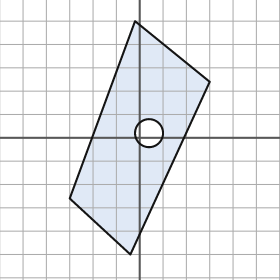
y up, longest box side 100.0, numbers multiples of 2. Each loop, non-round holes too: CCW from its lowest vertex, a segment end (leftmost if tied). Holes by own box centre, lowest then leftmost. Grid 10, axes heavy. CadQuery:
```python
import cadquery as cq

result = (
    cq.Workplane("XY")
    .moveTo(-4.0, -50.0)
    .lineTo(30.0, 24.0)
    .lineTo(-2.0, 50.0)
    .lineTo(-30.0, -26.0)
    .close()
    .moveTo(4.0, 2.0)
    .circle(6.0)
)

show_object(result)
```